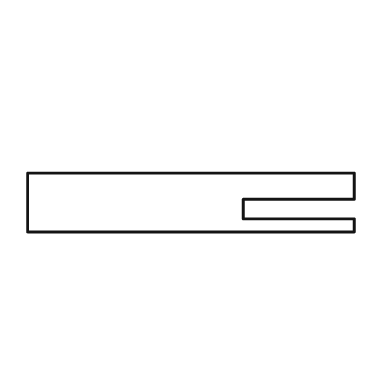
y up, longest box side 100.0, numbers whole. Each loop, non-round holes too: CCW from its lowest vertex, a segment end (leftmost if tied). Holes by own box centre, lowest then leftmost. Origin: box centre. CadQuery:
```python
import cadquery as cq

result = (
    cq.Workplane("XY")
    .moveTo(-50.0, -9.0)
    .lineTo(50.0, -9.0)
    .lineTo(50.0, -5.0)
    .lineTo(16.0, -5.0)
    .lineTo(16.0, 1.0)
    .lineTo(50.0, 1.0)
    .lineTo(50.0, 9.0)
    .lineTo(-50.0, 9.0)
    .close()
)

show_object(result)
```